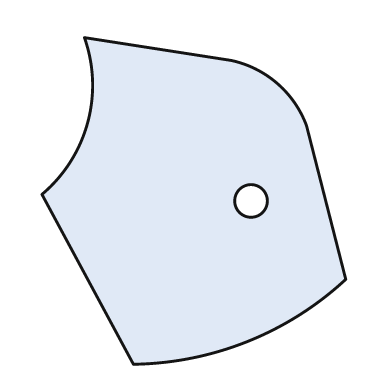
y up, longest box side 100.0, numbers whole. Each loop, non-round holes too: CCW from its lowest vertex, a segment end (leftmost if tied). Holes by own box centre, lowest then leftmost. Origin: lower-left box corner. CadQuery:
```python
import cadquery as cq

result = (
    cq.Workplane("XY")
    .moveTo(28.0, 0.0)
    .threePointArc((63.0, 7.0), (93.0, 26.0))
    .lineTo(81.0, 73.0)
    .threePointArc((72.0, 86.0), (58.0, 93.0))
    .lineTo(13.0, 100.0)
    .threePointArc((14.0, 74.0), (0.0, 52.0))
    .close()
    .moveTo(64.0, 50.0)
    .circle(5.0)
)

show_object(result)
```